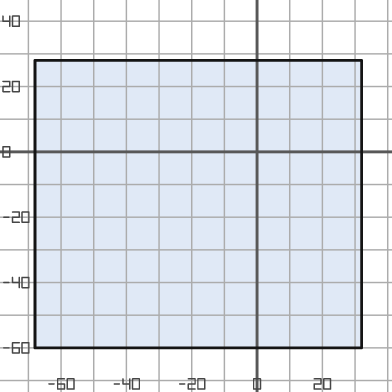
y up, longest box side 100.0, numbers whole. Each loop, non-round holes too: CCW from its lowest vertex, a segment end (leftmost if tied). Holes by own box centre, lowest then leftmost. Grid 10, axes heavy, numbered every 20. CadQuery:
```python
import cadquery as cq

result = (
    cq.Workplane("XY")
    .moveTo(-68.0, -60.0)
    .lineTo(32.0, -60.0)
    .lineTo(32.0, 28.0)
    .lineTo(-68.0, 28.0)
    .close()
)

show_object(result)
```